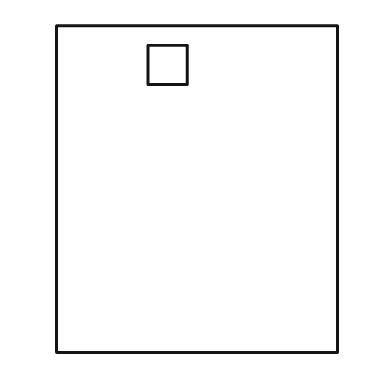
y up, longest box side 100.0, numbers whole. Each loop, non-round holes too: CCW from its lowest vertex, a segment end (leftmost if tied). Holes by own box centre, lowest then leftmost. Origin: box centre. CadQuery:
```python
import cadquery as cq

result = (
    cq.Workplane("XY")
    .moveTo(-43.0, -50.0)
    .lineTo(43.0, -50.0)
    .lineTo(43.0, 50.0)
    .lineTo(-43.0, 50.0)
    .close()
    .moveTo(-15.0, 32.0)
    .lineTo(-3.0, 32.0)
    .lineTo(-3.0, 44.0)
    .lineTo(-15.0, 44.0)
    .close()
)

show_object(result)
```